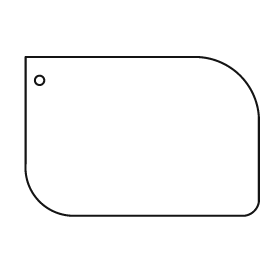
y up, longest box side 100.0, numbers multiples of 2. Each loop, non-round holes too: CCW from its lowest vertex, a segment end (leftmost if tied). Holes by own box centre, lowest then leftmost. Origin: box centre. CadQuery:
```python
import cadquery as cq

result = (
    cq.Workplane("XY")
    .moveTo(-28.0, -34.0)
    .lineTo(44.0, -34.0)
    .threePointArc((48.0, -32.0), (50.0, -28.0))
    .lineTo(50.0, 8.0)
    .threePointArc((42.0, 26.0), (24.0, 34.0))
    .lineTo(-50.0, 34.0)
    .lineTo(-50.0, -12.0)
    .threePointArc((-44.0, -28.0), (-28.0, -34.0))
    .close()
    .moveTo(-44.0, 24.0)
    .circle(2.0)
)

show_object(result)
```